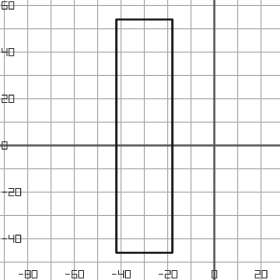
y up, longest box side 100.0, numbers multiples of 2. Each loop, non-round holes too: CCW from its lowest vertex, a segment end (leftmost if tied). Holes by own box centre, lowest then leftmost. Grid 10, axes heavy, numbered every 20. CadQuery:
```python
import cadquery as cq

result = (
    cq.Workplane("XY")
    .moveTo(-42.0, -46.0)
    .lineTo(-18.0, -46.0)
    .lineTo(-18.0, 54.0)
    .lineTo(-42.0, 54.0)
    .close()
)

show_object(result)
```